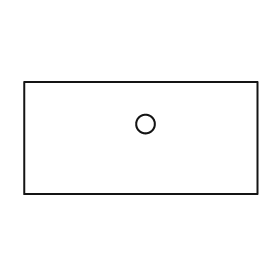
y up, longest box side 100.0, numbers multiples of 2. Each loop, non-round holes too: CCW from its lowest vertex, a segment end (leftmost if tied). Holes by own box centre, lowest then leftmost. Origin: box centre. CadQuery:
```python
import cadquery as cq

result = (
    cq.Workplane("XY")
    .moveTo(-50.0, -24.0)
    .lineTo(50.0, -24.0)
    .lineTo(50.0, 24.0)
    .lineTo(-50.0, 24.0)
    .close()
    .moveTo(2.0, 6.0)
    .circle(4.0)
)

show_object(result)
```